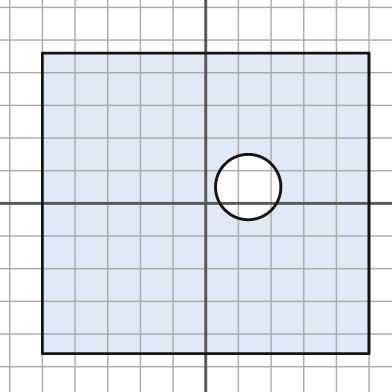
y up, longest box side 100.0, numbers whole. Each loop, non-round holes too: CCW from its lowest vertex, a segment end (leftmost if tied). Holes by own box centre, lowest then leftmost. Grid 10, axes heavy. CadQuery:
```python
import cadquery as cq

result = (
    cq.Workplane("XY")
    .moveTo(-50.0, -46.0)
    .lineTo(50.0, -46.0)
    .lineTo(50.0, 46.0)
    .lineTo(-50.0, 46.0)
    .close()
    .moveTo(13.0, 5.0)
    .circle(10.0)
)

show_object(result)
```